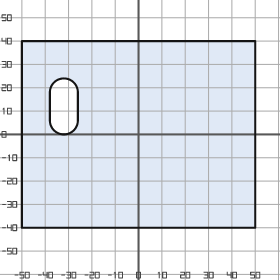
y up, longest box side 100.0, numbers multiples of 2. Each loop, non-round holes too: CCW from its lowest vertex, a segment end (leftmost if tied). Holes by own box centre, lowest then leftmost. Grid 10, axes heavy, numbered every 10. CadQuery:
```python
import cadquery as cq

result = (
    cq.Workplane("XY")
    .moveTo(-50.0, -40.0)
    .lineTo(50.0, -40.0)
    .lineTo(50.0, 40.0)
    .lineTo(-50.0, 40.0)
    .close()
    .moveTo(-38.0, 6.0)
    .threePointArc((-32.0, 0.0), (-26.0, 6.0))
    .lineTo(-26.0, 18.0)
    .threePointArc((-32.0, 24.0), (-38.0, 18.0))
    .close()
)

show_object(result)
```